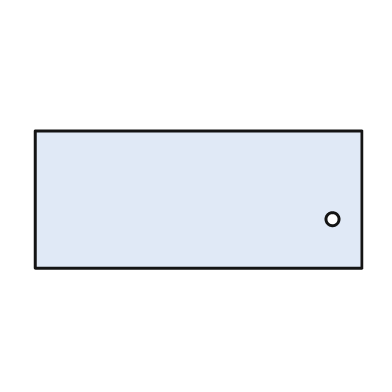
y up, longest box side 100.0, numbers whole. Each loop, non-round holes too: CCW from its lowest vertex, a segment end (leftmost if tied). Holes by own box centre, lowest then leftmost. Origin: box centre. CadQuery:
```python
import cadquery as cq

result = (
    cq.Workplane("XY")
    .moveTo(-50.0, -21.0)
    .lineTo(50.0, -21.0)
    .lineTo(50.0, 21.0)
    .lineTo(-50.0, 21.0)
    .close()
    .moveTo(41.0, -6.0)
    .circle(2.0)
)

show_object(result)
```